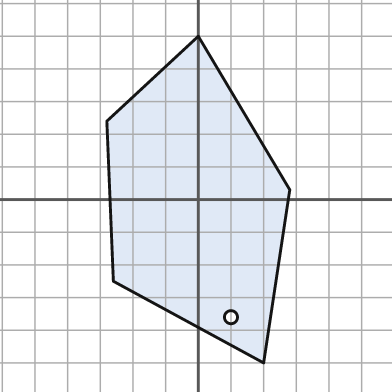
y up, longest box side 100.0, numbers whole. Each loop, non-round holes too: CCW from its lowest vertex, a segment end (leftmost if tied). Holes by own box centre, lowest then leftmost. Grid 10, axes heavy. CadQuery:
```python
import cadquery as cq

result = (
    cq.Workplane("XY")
    .moveTo(20.0, -50.0)
    .lineTo(28.0, 3.0)
    .lineTo(0.0, 50.0)
    .lineTo(-28.0, 24.0)
    .lineTo(-26.0, -25.0)
    .close()
    .moveTo(10.0, -36.0)
    .circle(2.0)
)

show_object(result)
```